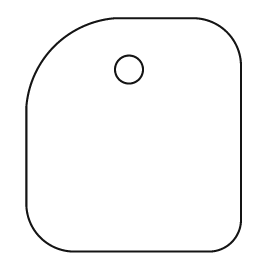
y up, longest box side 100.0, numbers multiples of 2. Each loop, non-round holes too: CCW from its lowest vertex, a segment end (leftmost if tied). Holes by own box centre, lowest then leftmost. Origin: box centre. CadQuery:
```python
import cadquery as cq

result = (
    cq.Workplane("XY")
    .moveTo(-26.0, -50.0)
    .lineTo(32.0, -50.0)
    .threePointArc((42.0, -46.0), (46.0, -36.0))
    .lineTo(46.0, 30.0)
    .threePointArc((40.0, 44.0), (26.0, 50.0))
    .lineTo(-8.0, 50.0)
    .threePointArc((-34.0, 38.0), (-46.0, 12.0))
    .lineTo(-46.0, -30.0)
    .threePointArc((-40.0, -44.0), (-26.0, -50.0))
    .close()
    .moveTo(-2.0, 28.0)
    .circle(6.0)
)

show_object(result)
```